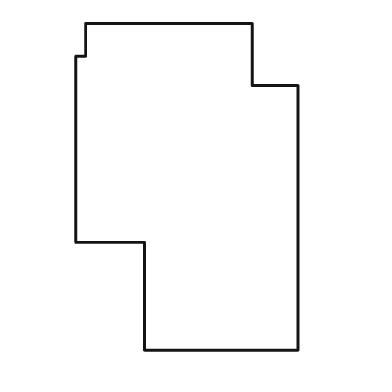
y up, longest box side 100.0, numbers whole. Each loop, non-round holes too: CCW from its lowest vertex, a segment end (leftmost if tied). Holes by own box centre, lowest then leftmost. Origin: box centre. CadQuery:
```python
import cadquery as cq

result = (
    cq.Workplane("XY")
    .moveTo(-13.0, -50.0)
    .lineTo(34.0, -50.0)
    .lineTo(34.0, 31.0)
    .lineTo(20.0, 31.0)
    .lineTo(20.0, 50.0)
    .lineTo(-31.0, 50.0)
    .lineTo(-31.0, 40.0)
    .lineTo(-34.0, 40.0)
    .lineTo(-34.0, -17.0)
    .lineTo(-13.0, -17.0)
    .close()
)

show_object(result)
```